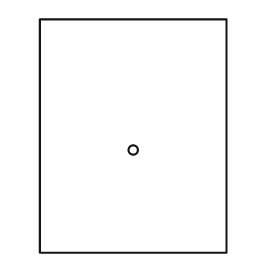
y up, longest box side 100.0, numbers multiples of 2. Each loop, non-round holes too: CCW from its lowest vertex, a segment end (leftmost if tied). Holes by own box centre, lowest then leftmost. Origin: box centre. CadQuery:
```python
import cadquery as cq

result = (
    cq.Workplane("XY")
    .moveTo(-40.0, -50.0)
    .lineTo(40.0, -50.0)
    .lineTo(40.0, 50.0)
    .lineTo(-40.0, 50.0)
    .close()
    .moveTo(0.0, -6.0)
    .circle(2.0)
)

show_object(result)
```